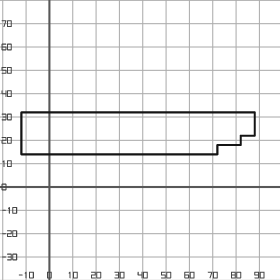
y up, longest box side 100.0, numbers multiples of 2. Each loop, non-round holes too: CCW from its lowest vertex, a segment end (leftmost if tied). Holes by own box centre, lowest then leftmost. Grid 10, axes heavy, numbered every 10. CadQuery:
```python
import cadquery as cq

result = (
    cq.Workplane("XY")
    .moveTo(-12.0, 14.0)
    .lineTo(72.0, 14.0)
    .lineTo(72.0, 18.0)
    .lineTo(82.0, 18.0)
    .lineTo(82.0, 22.0)
    .lineTo(88.0, 22.0)
    .lineTo(88.0, 32.0)
    .lineTo(-12.0, 32.0)
    .close()
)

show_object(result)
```